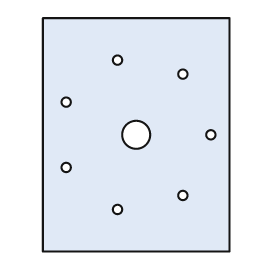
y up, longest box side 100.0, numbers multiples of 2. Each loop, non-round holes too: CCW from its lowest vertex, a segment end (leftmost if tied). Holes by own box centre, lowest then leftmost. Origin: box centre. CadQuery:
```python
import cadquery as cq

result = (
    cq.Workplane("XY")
    .moveTo(-40.0, -50.0)
    .lineTo(40.0, -50.0)
    .lineTo(40.0, 50.0)
    .lineTo(-40.0, 50.0)
    .close()
    .moveTo(-8.0, -32.0)
    .circle(2.0)
    .moveTo(20.0, -26.0)
    .circle(2.0)
    .moveTo(-30.0, -14.0)
    .circle(2.0)
    .moveTo(0.0, 0.0)
    .circle(6.0)
    .moveTo(32.0, 0.0)
    .circle(2.0)
    .moveTo(-30.0, 14.0)
    .circle(2.0)
    .moveTo(20.0, 26.0)
    .circle(2.0)
    .moveTo(-8.0, 32.0)
    .circle(2.0)
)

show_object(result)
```